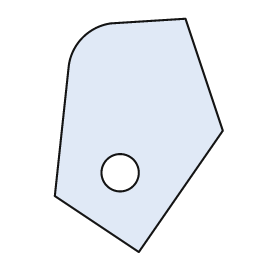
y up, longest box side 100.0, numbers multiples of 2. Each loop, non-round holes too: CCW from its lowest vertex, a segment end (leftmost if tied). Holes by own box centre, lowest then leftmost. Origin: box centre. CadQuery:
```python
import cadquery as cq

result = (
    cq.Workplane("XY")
    .moveTo(0.0, -50.0)
    .lineTo(36.0, 2.0)
    .lineTo(20.0, 50.0)
    .lineTo(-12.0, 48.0)
    .threePointArc((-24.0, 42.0), (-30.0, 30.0))
    .lineTo(-36.0, -26.0)
    .close()
    .moveTo(-8.0, -16.0)
    .circle(8.0)
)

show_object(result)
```